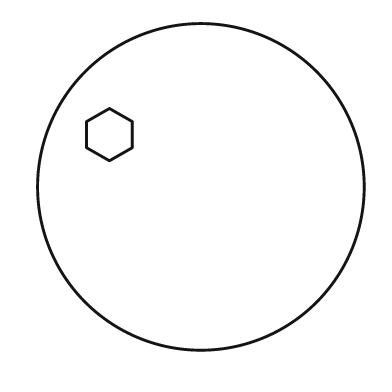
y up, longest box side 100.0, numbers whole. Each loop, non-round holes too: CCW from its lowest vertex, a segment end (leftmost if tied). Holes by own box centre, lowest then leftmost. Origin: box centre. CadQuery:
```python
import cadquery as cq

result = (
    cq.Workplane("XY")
    .moveTo(0.0, 0.0)
    .circle(50.0)
    .moveTo(-28.0, 8.0)
    .lineTo(-21.0, 12.0)
    .lineTo(-21.0, 20.0)
    .lineTo(-28.0, 24.0)
    .lineTo(-35.0, 20.0)
    .lineTo(-35.0, 12.0)
    .close()
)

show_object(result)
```